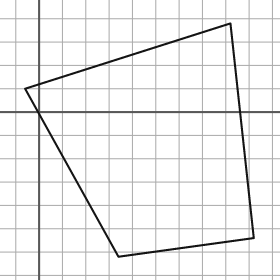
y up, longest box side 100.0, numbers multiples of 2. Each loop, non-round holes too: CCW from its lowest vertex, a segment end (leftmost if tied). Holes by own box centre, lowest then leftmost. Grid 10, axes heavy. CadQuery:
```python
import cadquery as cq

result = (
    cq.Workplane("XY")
    .moveTo(34.0, -62.0)
    .lineTo(92.0, -54.0)
    .lineTo(82.0, 38.0)
    .lineTo(-6.0, 10.0)
    .close()
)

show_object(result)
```